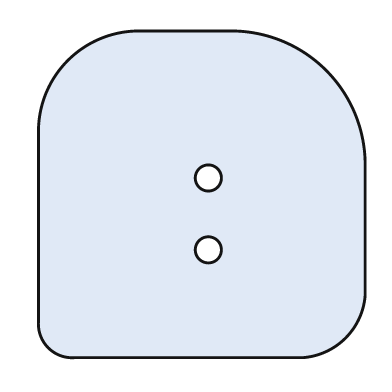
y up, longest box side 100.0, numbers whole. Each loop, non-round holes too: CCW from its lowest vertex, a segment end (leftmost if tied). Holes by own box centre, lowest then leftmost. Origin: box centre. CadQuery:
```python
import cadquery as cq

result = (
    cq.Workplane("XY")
    .moveTo(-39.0, -50.0)
    .lineTo(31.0, -50.0)
    .threePointArc((44.0, -44.0), (50.0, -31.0))
    .lineTo(50.0, 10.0)
    .threePointArc((38.0, 38.0), (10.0, 50.0))
    .lineTo(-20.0, 50.0)
    .threePointArc((-41.0, 41.0), (-50.0, 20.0))
    .lineTo(-50.0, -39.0)
    .threePointArc((-47.0, -47.0), (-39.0, -50.0))
    .close()
    .moveTo(2.0, -17.0)
    .circle(4.0)
    .moveTo(2.0, 5.0)
    .circle(4.0)
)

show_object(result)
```